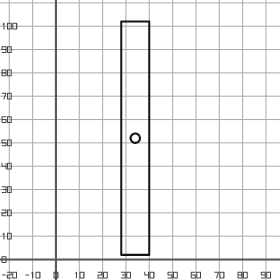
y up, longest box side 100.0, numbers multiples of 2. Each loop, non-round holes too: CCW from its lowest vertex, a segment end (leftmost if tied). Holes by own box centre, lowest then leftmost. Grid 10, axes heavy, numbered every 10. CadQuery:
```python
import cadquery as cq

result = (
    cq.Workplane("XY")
    .moveTo(28.0, 2.0)
    .lineTo(40.0, 2.0)
    .lineTo(40.0, 102.0)
    .lineTo(28.0, 102.0)
    .close()
    .moveTo(34.0, 52.0)
    .circle(2.0)
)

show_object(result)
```